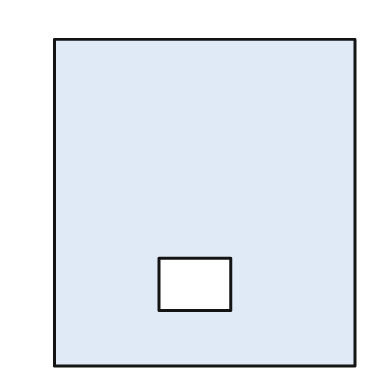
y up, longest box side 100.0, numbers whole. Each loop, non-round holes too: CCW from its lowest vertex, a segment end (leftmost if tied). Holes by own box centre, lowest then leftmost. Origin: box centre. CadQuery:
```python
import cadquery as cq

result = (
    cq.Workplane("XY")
    .moveTo(-46.0, -50.0)
    .lineTo(46.0, -50.0)
    .lineTo(46.0, 50.0)
    .lineTo(-46.0, 50.0)
    .close()
    .moveTo(-14.0, -33.0)
    .lineTo(8.0, -33.0)
    .lineTo(8.0, -17.0)
    .lineTo(-14.0, -17.0)
    .close()
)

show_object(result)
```